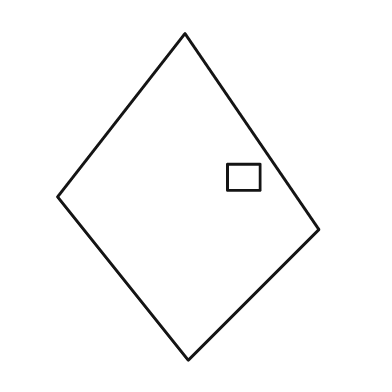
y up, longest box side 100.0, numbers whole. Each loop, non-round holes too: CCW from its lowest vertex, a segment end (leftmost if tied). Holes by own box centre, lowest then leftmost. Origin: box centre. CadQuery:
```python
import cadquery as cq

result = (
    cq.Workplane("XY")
    .moveTo(0.0, -50.0)
    .lineTo(40.0, -10.0)
    .lineTo(-1.0, 50.0)
    .lineTo(-40.0, 0.0)
    .close()
    .moveTo(12.0, 2.0)
    .lineTo(22.0, 2.0)
    .lineTo(22.0, 10.0)
    .lineTo(12.0, 10.0)
    .close()
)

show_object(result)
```